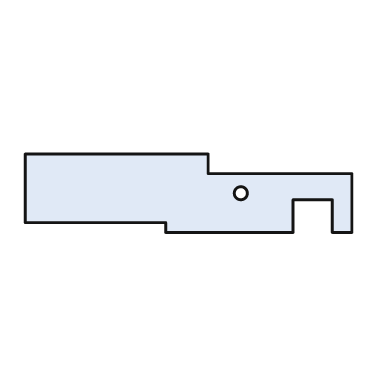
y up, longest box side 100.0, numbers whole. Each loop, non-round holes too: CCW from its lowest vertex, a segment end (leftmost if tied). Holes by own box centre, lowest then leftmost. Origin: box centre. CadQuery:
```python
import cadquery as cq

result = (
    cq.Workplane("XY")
    .moveTo(-7.0, -12.0)
    .lineTo(32.0, -12.0)
    .lineTo(32.0, -2.0)
    .lineTo(44.0, -2.0)
    .lineTo(44.0, -12.0)
    .lineTo(50.0, -12.0)
    .lineTo(50.0, 6.0)
    .lineTo(6.0, 6.0)
    .lineTo(6.0, 12.0)
    .lineTo(-50.0, 12.0)
    .lineTo(-50.0, -9.0)
    .lineTo(-7.0, -9.0)
    .close()
    .moveTo(16.0, 0.0)
    .circle(2.0)
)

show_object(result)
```